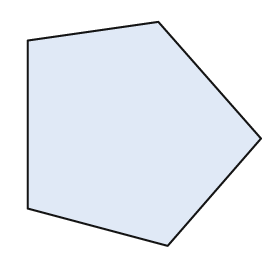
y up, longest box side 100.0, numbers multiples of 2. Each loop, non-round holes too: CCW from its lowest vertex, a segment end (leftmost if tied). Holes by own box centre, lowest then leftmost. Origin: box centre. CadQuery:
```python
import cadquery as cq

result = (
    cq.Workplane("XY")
    .moveTo(10.0, -48.0)
    .lineTo(50.0, -2.0)
    .lineTo(6.0, 48.0)
    .lineTo(-50.0, 40.0)
    .lineTo(-50.0, -32.0)
    .close()
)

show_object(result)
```